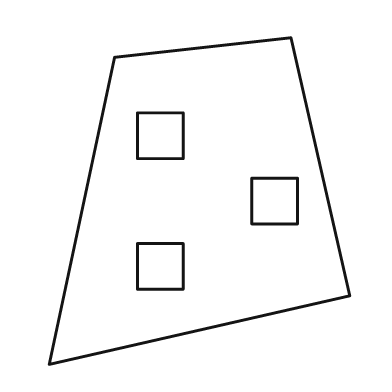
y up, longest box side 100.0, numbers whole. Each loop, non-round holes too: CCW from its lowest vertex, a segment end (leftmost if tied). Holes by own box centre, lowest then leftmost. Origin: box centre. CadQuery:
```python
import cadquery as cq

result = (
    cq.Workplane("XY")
    .moveTo(-46.0, -50.0)
    .lineTo(46.0, -29.0)
    .lineTo(28.0, 50.0)
    .lineTo(-26.0, 44.0)
    .close()
    .moveTo(-19.0, -27.0)
    .lineTo(-5.0, -27.0)
    .lineTo(-5.0, -13.0)
    .lineTo(-19.0, -13.0)
    .close()
    .moveTo(16.0, -7.0)
    .lineTo(30.0, -7.0)
    .lineTo(30.0, 7.0)
    .lineTo(16.0, 7.0)
    .close()
    .moveTo(-19.0, 13.0)
    .lineTo(-5.0, 13.0)
    .lineTo(-5.0, 27.0)
    .lineTo(-19.0, 27.0)
    .close()
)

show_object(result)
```